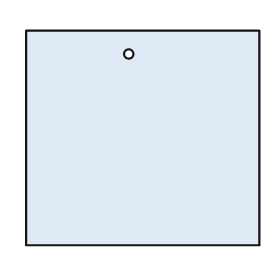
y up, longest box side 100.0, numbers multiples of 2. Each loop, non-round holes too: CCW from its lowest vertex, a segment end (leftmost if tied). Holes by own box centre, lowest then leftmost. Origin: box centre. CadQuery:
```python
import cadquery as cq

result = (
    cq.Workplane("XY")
    .moveTo(-50.0, -46.0)
    .lineTo(50.0, -46.0)
    .lineTo(50.0, 46.0)
    .lineTo(-50.0, 46.0)
    .close()
    .moveTo(-6.0, 36.0)
    .circle(2.0)
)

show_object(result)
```